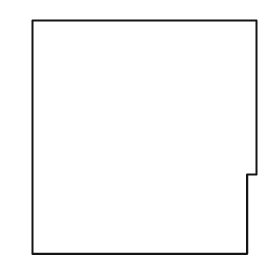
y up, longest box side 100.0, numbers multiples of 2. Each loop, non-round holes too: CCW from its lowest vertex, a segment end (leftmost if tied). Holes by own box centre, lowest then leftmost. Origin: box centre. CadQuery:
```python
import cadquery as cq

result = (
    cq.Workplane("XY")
    .moveTo(-48.0, -50.0)
    .lineTo(44.0, -50.0)
    .lineTo(44.0, -16.0)
    .lineTo(48.0, -16.0)
    .lineTo(48.0, 50.0)
    .lineTo(-48.0, 50.0)
    .close()
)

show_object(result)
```